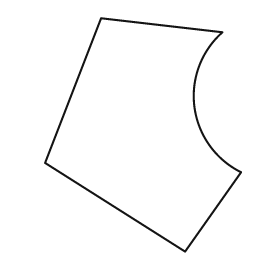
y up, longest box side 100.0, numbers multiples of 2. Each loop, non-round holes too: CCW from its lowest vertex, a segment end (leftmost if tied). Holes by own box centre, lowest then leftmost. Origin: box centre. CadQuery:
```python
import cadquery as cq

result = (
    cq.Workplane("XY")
    .moveTo(18.0, -50.0)
    .lineTo(42.0, -16.0)
    .threePointArc((22.0, 12.0), (34.0, 44.0))
    .lineTo(-18.0, 50.0)
    .lineTo(-42.0, -12.0)
    .close()
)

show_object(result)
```